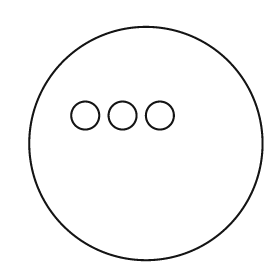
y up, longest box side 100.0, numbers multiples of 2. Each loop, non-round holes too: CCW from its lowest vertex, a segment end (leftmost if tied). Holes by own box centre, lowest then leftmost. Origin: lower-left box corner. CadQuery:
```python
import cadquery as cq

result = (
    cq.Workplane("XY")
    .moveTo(50.0, 50.0)
    .circle(50.0)
    .moveTo(24.0, 62.0)
    .circle(6.0)
    .moveTo(40.0, 62.0)
    .circle(6.0)
    .moveTo(56.0, 62.0)
    .circle(6.0)
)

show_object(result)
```